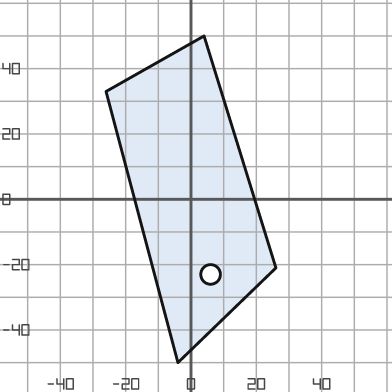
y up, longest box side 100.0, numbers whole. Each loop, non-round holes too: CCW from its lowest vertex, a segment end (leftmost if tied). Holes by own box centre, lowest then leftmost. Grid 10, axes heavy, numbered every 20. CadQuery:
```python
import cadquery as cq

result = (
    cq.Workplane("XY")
    .moveTo(-4.0, -50.0)
    .lineTo(26.0, -21.0)
    .lineTo(4.0, 50.0)
    .lineTo(-26.0, 33.0)
    .close()
    .moveTo(6.0, -23.0)
    .circle(3.0)
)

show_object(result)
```